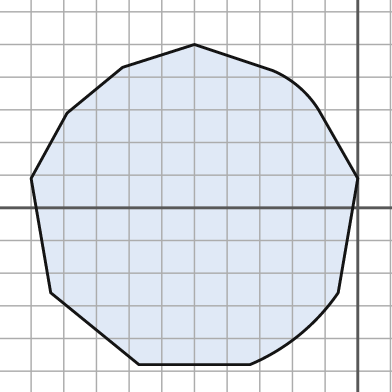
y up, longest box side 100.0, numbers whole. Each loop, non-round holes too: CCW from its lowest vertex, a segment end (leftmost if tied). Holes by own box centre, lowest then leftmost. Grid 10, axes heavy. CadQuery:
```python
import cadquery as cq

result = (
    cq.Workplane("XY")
    .moveTo(-67.0, -48.0)
    .lineTo(-33.0, -48.0)
    .threePointArc((-18.0, -39.0), (-6.0, -26.0))
    .lineTo(0.0, 9.0)
    .lineTo(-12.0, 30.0)
    .threePointArc((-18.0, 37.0), (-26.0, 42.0))
    .lineTo(-50.0, 50.0)
    .lineTo(-72.0, 43.0)
    .lineTo(-89.0, 29.0)
    .lineTo(-100.0, 9.0)
    .lineTo(-94.0, -26.0)
    .close()
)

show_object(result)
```